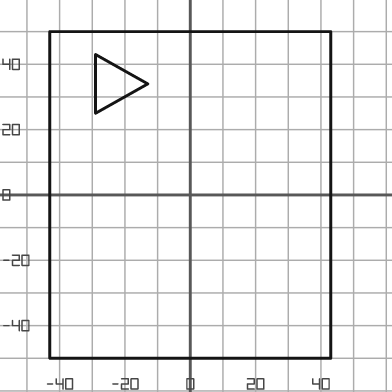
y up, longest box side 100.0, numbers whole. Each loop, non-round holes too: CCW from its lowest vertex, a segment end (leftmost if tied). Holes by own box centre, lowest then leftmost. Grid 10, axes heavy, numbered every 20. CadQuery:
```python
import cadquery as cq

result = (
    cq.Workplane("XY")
    .moveTo(-43.0, -50.0)
    .lineTo(43.0, -50.0)
    .lineTo(43.0, 50.0)
    .lineTo(-43.0, 50.0)
    .close()
    .moveTo(-29.0, 25.0)
    .lineTo(-13.0, 34.0)
    .lineTo(-29.0, 43.0)
    .close()
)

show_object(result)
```